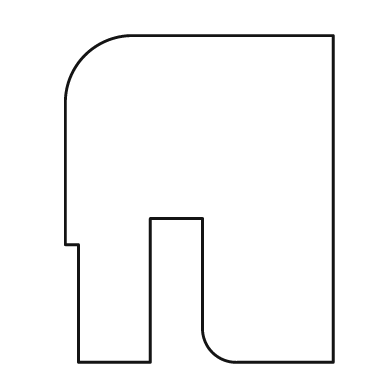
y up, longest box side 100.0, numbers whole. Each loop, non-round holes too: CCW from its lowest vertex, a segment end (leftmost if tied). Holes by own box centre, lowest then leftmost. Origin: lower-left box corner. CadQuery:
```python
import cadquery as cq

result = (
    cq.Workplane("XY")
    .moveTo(4.0, 0.0)
    .lineTo(26.0, 0.0)
    .lineTo(26.0, 44.0)
    .lineTo(42.0, 44.0)
    .lineTo(42.0, 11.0)
    .threePointArc((45.0, 3.0), (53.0, 0.0))
    .lineTo(82.0, 0.0)
    .lineTo(82.0, 100.0)
    .lineTo(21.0, 100.0)
    .threePointArc((6.0, 94.0), (0.0, 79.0))
    .lineTo(0.0, 36.0)
    .lineTo(4.0, 36.0)
    .close()
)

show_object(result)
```